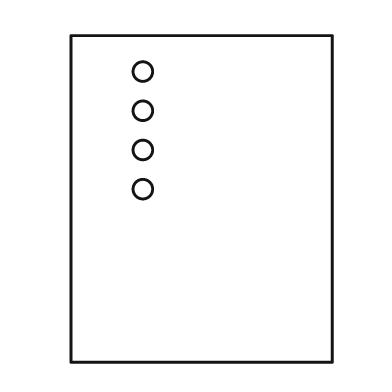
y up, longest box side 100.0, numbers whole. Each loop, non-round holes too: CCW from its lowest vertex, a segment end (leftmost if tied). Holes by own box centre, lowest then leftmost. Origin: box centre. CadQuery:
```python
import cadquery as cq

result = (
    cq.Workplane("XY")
    .moveTo(-40.0, -50.0)
    .lineTo(40.0, -50.0)
    .lineTo(40.0, 50.0)
    .lineTo(-40.0, 50.0)
    .close()
    .moveTo(-18.0, 3.0)
    .circle(3.0)
    .moveTo(-18.0, 15.0)
    .circle(3.0)
    .moveTo(-18.0, 27.0)
    .circle(3.0)
    .moveTo(-18.0, 39.0)
    .circle(3.0)
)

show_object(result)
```